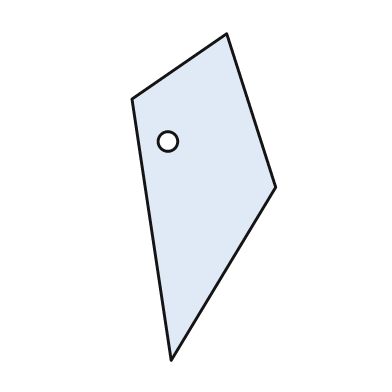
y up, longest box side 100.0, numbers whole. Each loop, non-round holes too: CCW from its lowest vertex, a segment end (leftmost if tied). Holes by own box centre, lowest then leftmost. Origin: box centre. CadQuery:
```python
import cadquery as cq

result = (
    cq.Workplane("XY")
    .moveTo(-10.0, -50.0)
    .lineTo(22.0, 3.0)
    .lineTo(7.0, 50.0)
    .lineTo(-22.0, 30.0)
    .close()
    .moveTo(-11.0, 17.0)
    .circle(3.0)
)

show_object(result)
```